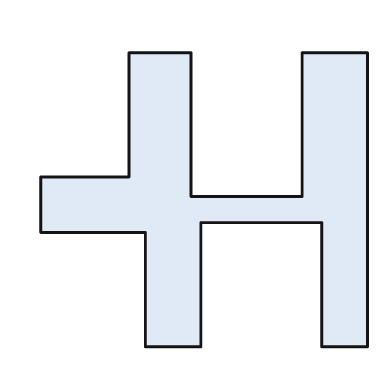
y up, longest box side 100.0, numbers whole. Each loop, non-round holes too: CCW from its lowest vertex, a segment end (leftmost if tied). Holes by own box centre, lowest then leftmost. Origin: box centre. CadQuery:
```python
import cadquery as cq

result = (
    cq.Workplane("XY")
    .moveTo(-18.0, -45.0)
    .lineTo(-1.0, -45.0)
    .lineTo(-1.0, -7.0)
    .lineTo(36.0, -7.0)
    .lineTo(36.0, -45.0)
    .lineTo(50.0, -45.0)
    .lineTo(50.0, 45.0)
    .lineTo(30.0, 45.0)
    .lineTo(30.0, 1.0)
    .lineTo(-4.0, 1.0)
    .lineTo(-4.0, 45.0)
    .lineTo(-23.0, 45.0)
    .lineTo(-23.0, 7.0)
    .lineTo(-50.0, 7.0)
    .lineTo(-50.0, -10.0)
    .lineTo(-18.0, -10.0)
    .close()
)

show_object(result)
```